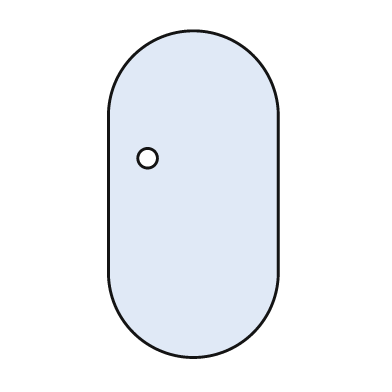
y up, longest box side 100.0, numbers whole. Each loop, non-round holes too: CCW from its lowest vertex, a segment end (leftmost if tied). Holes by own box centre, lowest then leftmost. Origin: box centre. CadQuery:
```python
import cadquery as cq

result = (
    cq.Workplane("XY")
    .moveTo(-26.0, -24.0)
    .threePointArc((0.0, -50.0), (26.0, -24.0))
    .lineTo(26.0, 24.0)
    .threePointArc((0.0, 50.0), (-26.0, 24.0))
    .close()
    .moveTo(-14.0, 11.0)
    .circle(3.0)
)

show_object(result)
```